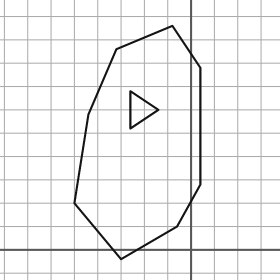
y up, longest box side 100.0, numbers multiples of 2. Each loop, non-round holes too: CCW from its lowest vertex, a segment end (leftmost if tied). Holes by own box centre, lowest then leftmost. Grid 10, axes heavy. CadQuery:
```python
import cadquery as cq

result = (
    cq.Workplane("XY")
    .moveTo(-30.0, -4.0)
    .lineTo(-6.0, 10.0)
    .lineTo(4.0, 28.0)
    .lineTo(4.0, 78.0)
    .lineTo(-8.0, 96.0)
    .lineTo(-32.0, 86.0)
    .lineTo(-44.0, 58.0)
    .lineTo(-50.0, 20.0)
    .close()
    .moveTo(-26.0, 52.0)
    .lineTo(-14.0, 60.0)
    .lineTo(-26.0, 68.0)
    .close()
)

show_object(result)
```